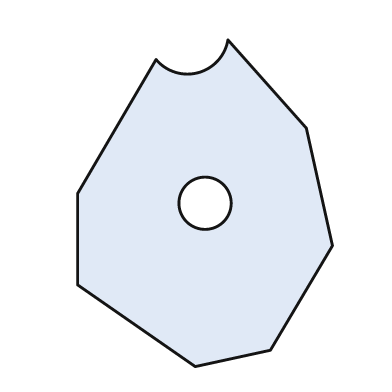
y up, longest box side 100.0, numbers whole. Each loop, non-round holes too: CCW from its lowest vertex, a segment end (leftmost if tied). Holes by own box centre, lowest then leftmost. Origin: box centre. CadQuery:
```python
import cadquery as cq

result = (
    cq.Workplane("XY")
    .moveTo(-3.0, -50.0)
    .lineTo(20.0, -45.0)
    .lineTo(39.0, -13.0)
    .lineTo(31.0, 23.0)
    .lineTo(7.0, 50.0)
    .threePointArc((-2.0, 40.0), (-15.0, 44.0))
    .lineTo(-39.0, 3.0)
    .lineTo(-39.0, -25.0)
    .close()
    .moveTo(0.0, 0.0)
    .circle(8.0)
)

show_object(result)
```